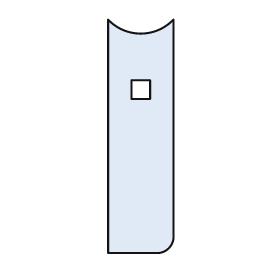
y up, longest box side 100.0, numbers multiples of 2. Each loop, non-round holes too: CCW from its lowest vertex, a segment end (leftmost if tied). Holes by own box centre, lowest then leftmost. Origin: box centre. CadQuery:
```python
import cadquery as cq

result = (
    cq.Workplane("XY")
    .moveTo(-14.0, -50.0)
    .lineTo(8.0, -50.0)
    .threePointArc((12.0, -48.0), (14.0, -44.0))
    .lineTo(14.0, 50.0)
    .threePointArc((0.0, 44.0), (-14.0, 50.0))
    .close()
    .moveTo(-4.0, 16.0)
    .lineTo(4.0, 16.0)
    .lineTo(4.0, 24.0)
    .lineTo(-4.0, 24.0)
    .close()
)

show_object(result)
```